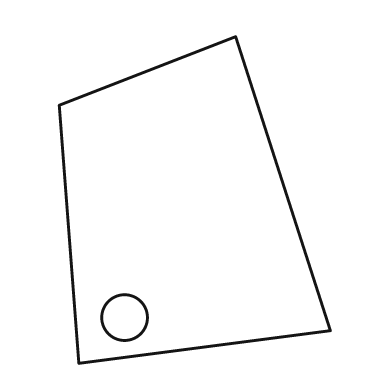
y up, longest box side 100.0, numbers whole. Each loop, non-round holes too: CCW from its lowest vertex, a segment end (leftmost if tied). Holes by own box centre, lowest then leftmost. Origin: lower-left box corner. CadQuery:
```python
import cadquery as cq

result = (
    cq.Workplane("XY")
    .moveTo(6.0, 0.0)
    .lineTo(83.0, 10.0)
    .lineTo(54.0, 100.0)
    .lineTo(0.0, 79.0)
    .close()
    .moveTo(20.0, 14.0)
    .circle(7.0)
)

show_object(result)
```